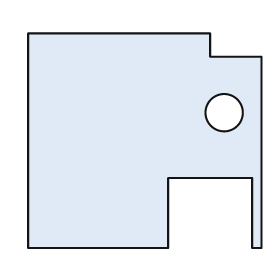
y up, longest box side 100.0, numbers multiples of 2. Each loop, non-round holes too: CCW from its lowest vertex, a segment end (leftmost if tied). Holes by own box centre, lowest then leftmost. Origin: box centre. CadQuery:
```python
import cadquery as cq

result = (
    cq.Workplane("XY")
    .moveTo(-50.0, -46.0)
    .lineTo(10.0, -46.0)
    .lineTo(10.0, -16.0)
    .lineTo(46.0, -16.0)
    .lineTo(46.0, -46.0)
    .lineTo(50.0, -46.0)
    .lineTo(50.0, 36.0)
    .lineTo(28.0, 36.0)
    .lineTo(28.0, 46.0)
    .lineTo(-50.0, 46.0)
    .close()
    .moveTo(34.0, 12.0)
    .circle(8.0)
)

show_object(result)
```